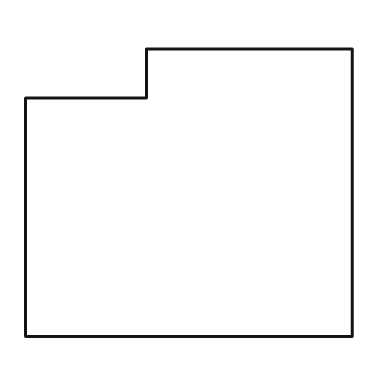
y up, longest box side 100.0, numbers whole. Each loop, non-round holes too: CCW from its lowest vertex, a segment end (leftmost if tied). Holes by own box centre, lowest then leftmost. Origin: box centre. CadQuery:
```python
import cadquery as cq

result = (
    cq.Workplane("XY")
    .moveTo(-50.0, -44.0)
    .lineTo(50.0, -44.0)
    .lineTo(50.0, 44.0)
    .lineTo(-13.0, 44.0)
    .lineTo(-13.0, 29.0)
    .lineTo(-50.0, 29.0)
    .close()
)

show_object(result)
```